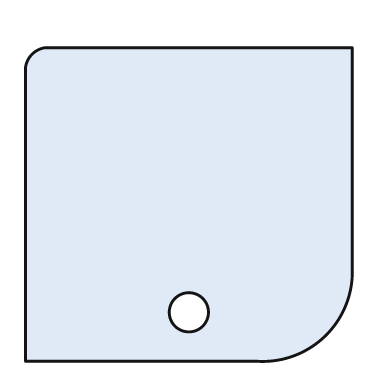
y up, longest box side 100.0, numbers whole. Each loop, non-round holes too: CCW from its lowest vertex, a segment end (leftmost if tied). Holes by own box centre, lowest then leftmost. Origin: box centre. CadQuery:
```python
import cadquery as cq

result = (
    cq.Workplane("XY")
    .moveTo(-50.0, -48.0)
    .lineTo(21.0, -48.0)
    .threePointArc((42.0, -40.0), (50.0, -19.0))
    .lineTo(50.0, 48.0)
    .lineTo(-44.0, 48.0)
    .threePointArc((-48.0, 46.0), (-50.0, 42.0))
    .close()
    .moveTo(0.0, -33.0)
    .circle(6.0)
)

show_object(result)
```